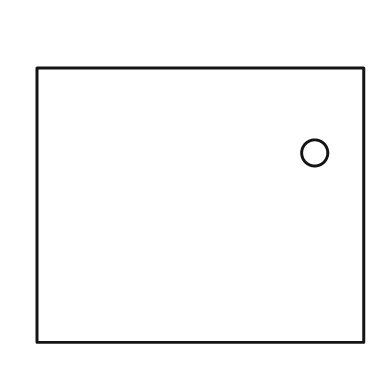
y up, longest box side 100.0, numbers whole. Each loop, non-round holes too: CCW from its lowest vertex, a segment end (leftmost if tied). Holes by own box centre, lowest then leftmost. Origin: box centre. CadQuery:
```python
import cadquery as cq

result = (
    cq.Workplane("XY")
    .moveTo(-50.0, -42.0)
    .lineTo(50.0, -42.0)
    .lineTo(50.0, 42.0)
    .lineTo(-50.0, 42.0)
    .close()
    .moveTo(35.0, 16.0)
    .circle(4.0)
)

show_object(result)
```